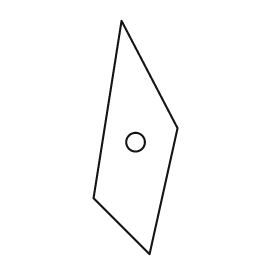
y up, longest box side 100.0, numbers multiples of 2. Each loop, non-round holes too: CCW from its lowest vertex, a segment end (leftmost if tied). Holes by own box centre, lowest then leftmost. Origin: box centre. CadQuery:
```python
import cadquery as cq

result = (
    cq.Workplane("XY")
    .moveTo(6.0, -50.0)
    .lineTo(18.0, 4.0)
    .lineTo(-6.0, 50.0)
    .lineTo(-18.0, -26.0)
    .close()
    .moveTo(0.0, -2.0)
    .circle(4.0)
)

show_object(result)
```